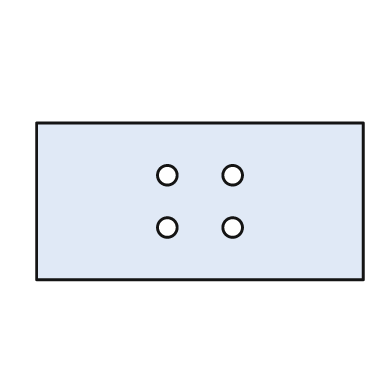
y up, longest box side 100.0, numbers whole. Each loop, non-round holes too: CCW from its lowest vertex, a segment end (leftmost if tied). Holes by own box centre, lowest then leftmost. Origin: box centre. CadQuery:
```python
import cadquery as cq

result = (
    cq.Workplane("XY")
    .moveTo(-50.0, -24.0)
    .lineTo(50.0, -24.0)
    .lineTo(50.0, 24.0)
    .lineTo(-50.0, 24.0)
    .close()
    .moveTo(-10.0, -8.0)
    .circle(3.0)
    .moveTo(10.0, -8.0)
    .circle(3.0)
    .moveTo(-10.0, 8.0)
    .circle(3.0)
    .moveTo(10.0, 8.0)
    .circle(3.0)
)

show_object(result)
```